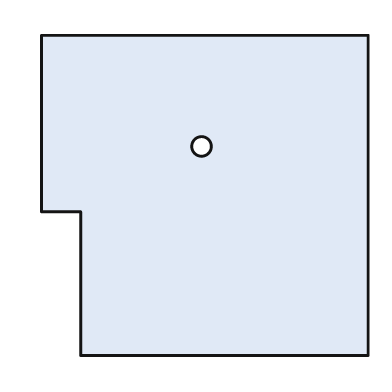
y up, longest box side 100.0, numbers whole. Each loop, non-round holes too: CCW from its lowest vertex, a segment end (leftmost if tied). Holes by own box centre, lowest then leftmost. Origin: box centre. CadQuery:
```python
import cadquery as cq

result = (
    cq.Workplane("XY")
    .moveTo(-38.0, -49.0)
    .lineTo(50.0, -49.0)
    .lineTo(50.0, 49.0)
    .lineTo(-50.0, 49.0)
    .lineTo(-50.0, -5.0)
    .lineTo(-38.0, -5.0)
    .close()
    .moveTo(-1.0, 15.0)
    .circle(3.0)
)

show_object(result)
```